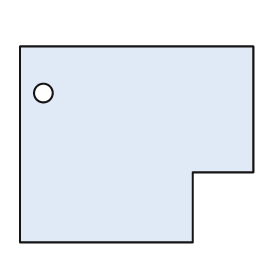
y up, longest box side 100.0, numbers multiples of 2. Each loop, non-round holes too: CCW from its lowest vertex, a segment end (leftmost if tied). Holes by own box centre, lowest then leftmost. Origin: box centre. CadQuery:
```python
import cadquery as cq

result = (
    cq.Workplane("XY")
    .moveTo(-50.0, -42.0)
    .lineTo(24.0, -42.0)
    .lineTo(24.0, -12.0)
    .lineTo(50.0, -12.0)
    .lineTo(50.0, 42.0)
    .lineTo(-50.0, 42.0)
    .close()
    .moveTo(-40.0, 22.0)
    .circle(4.0)
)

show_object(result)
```